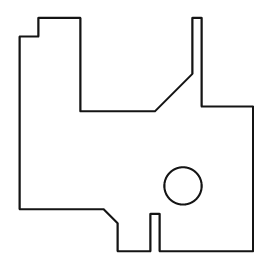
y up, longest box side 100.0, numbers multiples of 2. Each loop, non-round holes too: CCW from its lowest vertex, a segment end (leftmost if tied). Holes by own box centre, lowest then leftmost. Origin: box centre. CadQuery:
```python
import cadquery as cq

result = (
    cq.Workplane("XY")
    .moveTo(-8.0, -50.0)
    .lineTo(6.0, -50.0)
    .lineTo(6.0, -34.0)
    .lineTo(10.0, -34.0)
    .lineTo(10.0, -50.0)
    .lineTo(50.0, -50.0)
    .lineTo(50.0, 12.0)
    .lineTo(28.0, 12.0)
    .lineTo(28.0, 50.0)
    .lineTo(24.0, 50.0)
    .lineTo(24.0, 26.0)
    .lineTo(8.0, 10.0)
    .lineTo(-24.0, 10.0)
    .lineTo(-24.0, 50.0)
    .lineTo(-42.0, 50.0)
    .lineTo(-42.0, 42.0)
    .lineTo(-50.0, 42.0)
    .lineTo(-50.0, -32.0)
    .lineTo(-14.0, -32.0)
    .lineTo(-8.0, -38.0)
    .close()
    .moveTo(20.0, -22.0)
    .circle(8.0)
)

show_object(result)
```